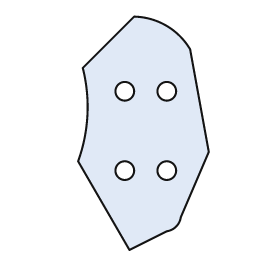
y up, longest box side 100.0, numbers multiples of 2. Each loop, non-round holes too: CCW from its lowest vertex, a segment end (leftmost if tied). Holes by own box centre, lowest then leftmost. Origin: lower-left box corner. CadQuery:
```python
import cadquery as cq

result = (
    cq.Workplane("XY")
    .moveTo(22.0, 0.0)
    .lineTo(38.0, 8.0)
    .threePointArc((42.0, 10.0), (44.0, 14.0))
    .lineTo(56.0, 42.0)
    .lineTo(48.0, 86.0)
    .threePointArc((38.0, 96.0), (24.0, 100.0))
    .lineTo(2.0, 78.0)
    .threePointArc((4.0, 58.0), (0.0, 38.0))
    .close()
    .moveTo(20.0, 34.0)
    .circle(4.0)
    .moveTo(38.0, 34.0)
    .circle(4.0)
    .moveTo(20.0, 68.0)
    .circle(4.0)
    .moveTo(38.0, 68.0)
    .circle(4.0)
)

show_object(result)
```